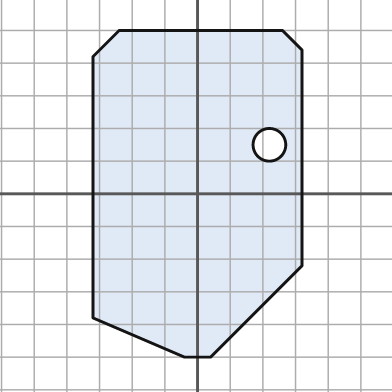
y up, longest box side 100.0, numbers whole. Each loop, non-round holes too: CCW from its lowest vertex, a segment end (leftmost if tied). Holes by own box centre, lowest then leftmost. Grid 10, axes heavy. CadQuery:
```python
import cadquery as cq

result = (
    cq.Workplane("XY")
    .moveTo(-4.0, -50.0)
    .lineTo(4.0, -50.0)
    .lineTo(32.0, -22.0)
    .lineTo(32.0, 44.0)
    .lineTo(26.0, 50.0)
    .lineTo(-24.0, 50.0)
    .lineTo(-32.0, 42.0)
    .lineTo(-32.0, -38.0)
    .close()
    .moveTo(22.0, 15.0)
    .circle(5.0)
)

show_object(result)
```